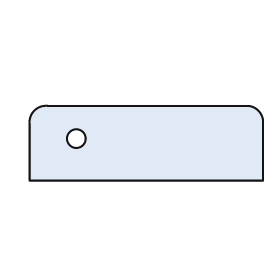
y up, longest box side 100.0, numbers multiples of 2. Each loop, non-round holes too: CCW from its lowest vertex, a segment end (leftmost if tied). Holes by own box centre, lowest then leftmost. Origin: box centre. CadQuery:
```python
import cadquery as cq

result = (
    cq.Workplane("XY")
    .moveTo(-50.0, -16.0)
    .lineTo(50.0, -16.0)
    .lineTo(50.0, 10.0)
    .threePointArc((48.0, 14.0), (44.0, 16.0))
    .lineTo(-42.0, 16.0)
    .threePointArc((-48.0, 14.0), (-50.0, 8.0))
    .close()
    .moveTo(-30.0, 2.0)
    .circle(4.0)
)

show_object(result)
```